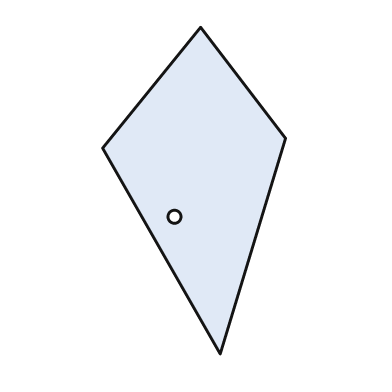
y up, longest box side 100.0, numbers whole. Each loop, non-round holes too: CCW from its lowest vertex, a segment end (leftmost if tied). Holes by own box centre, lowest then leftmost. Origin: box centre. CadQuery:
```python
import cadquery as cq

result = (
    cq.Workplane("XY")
    .moveTo(8.0, -50.0)
    .lineTo(28.0, 16.0)
    .lineTo(2.0, 50.0)
    .lineTo(-28.0, 13.0)
    .close()
    .moveTo(-6.0, -8.0)
    .circle(2.0)
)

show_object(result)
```